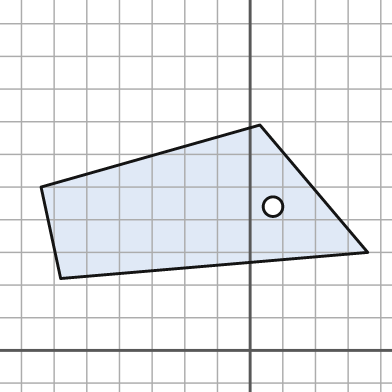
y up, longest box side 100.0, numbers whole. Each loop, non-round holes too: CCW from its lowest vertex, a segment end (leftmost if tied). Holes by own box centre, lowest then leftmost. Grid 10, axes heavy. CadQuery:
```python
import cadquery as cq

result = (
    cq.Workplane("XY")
    .moveTo(-58.0, 22.0)
    .lineTo(36.0, 30.0)
    .lineTo(3.0, 69.0)
    .lineTo(-64.0, 50.0)
    .close()
    .moveTo(7.0, 44.0)
    .circle(3.0)
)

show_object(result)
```